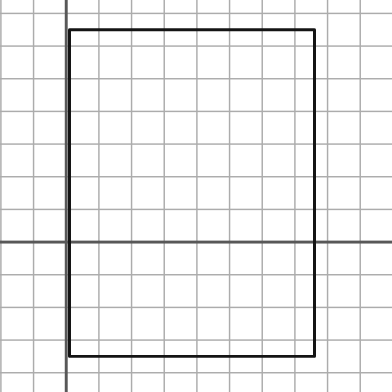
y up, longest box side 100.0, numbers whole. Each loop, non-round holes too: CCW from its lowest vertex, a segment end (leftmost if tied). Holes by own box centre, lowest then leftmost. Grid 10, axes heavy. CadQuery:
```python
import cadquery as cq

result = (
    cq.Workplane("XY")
    .moveTo(1.0, -35.0)
    .lineTo(76.0, -35.0)
    .lineTo(76.0, 65.0)
    .lineTo(1.0, 65.0)
    .close()
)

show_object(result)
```